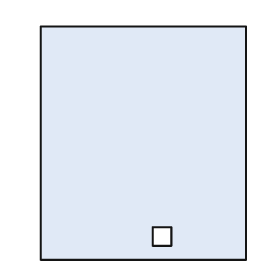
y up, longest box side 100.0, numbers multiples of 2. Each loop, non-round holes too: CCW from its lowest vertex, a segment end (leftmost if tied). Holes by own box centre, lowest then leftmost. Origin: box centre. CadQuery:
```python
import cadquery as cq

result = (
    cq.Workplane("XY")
    .moveTo(-44.0, -50.0)
    .lineTo(44.0, -50.0)
    .lineTo(44.0, 50.0)
    .lineTo(-44.0, 50.0)
    .close()
    .moveTo(4.0, -44.0)
    .lineTo(12.0, -44.0)
    .lineTo(12.0, -36.0)
    .lineTo(4.0, -36.0)
    .close()
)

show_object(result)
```